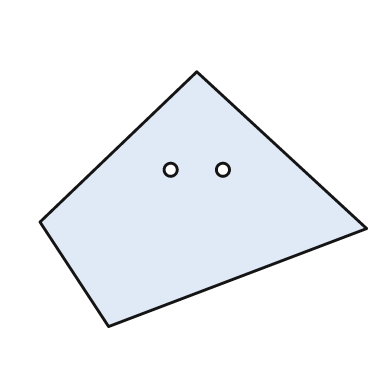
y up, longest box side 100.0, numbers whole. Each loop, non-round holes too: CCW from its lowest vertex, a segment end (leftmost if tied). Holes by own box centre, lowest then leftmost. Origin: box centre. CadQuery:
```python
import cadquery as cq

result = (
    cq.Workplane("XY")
    .moveTo(-29.0, -39.0)
    .lineTo(50.0, -9.0)
    .lineTo(-2.0, 39.0)
    .lineTo(-50.0, -7.0)
    .close()
    .moveTo(-10.0, 9.0)
    .circle(2.0)
    .moveTo(6.0, 9.0)
    .circle(2.0)
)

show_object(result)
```